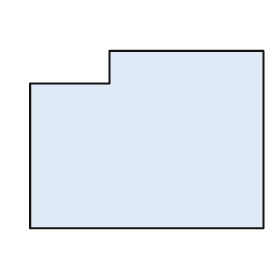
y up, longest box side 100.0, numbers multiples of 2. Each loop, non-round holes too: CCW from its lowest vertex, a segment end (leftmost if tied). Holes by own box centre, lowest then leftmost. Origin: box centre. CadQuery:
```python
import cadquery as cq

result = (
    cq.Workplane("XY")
    .moveTo(-50.0, -38.0)
    .lineTo(50.0, -38.0)
    .lineTo(50.0, 38.0)
    .lineTo(-16.0, 38.0)
    .lineTo(-16.0, 24.0)
    .lineTo(-50.0, 24.0)
    .close()
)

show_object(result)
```